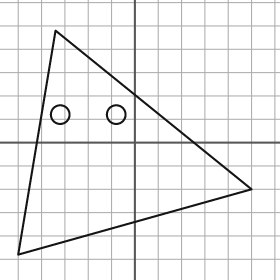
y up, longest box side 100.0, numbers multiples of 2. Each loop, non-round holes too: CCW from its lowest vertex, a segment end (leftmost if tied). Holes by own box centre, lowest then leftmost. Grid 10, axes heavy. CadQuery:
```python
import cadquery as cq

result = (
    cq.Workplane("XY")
    .moveTo(-50.0, -48.0)
    .lineTo(50.0, -20.0)
    .lineTo(-34.0, 48.0)
    .close()
    .moveTo(-32.0, 12.0)
    .circle(4.0)
    .moveTo(-8.0, 12.0)
    .circle(4.0)
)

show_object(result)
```